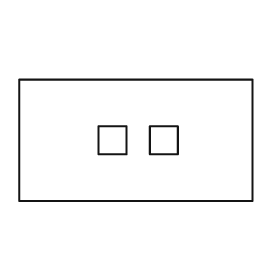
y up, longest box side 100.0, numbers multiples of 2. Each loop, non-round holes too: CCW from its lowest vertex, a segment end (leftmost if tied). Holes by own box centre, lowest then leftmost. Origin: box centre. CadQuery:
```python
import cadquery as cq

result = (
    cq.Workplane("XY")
    .moveTo(-50.0, -26.0)
    .lineTo(50.0, -26.0)
    .lineTo(50.0, 26.0)
    .lineTo(-50.0, 26.0)
    .close()
    .moveTo(-16.0, -6.0)
    .lineTo(-4.0, -6.0)
    .lineTo(-4.0, 6.0)
    .lineTo(-16.0, 6.0)
    .close()
    .moveTo(6.0, -6.0)
    .lineTo(18.0, -6.0)
    .lineTo(18.0, 6.0)
    .lineTo(6.0, 6.0)
    .close()
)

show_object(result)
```